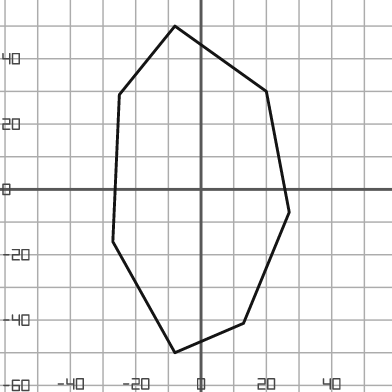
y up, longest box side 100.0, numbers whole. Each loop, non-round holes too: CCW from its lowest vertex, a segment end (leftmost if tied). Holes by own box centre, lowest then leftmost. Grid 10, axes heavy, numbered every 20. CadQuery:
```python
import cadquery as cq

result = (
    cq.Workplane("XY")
    .moveTo(-8.0, -50.0)
    .lineTo(13.0, -41.0)
    .lineTo(27.0, -7.0)
    .lineTo(20.0, 30.0)
    .lineTo(-8.0, 50.0)
    .lineTo(-25.0, 29.0)
    .lineTo(-27.0, -16.0)
    .close()
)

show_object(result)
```